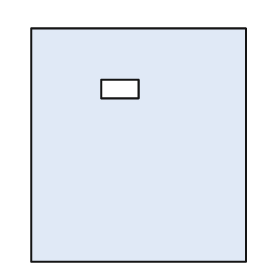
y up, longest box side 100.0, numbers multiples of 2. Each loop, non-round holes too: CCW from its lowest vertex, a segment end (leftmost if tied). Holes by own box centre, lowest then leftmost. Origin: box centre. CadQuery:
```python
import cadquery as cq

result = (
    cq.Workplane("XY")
    .moveTo(-46.0, -50.0)
    .lineTo(46.0, -50.0)
    .lineTo(46.0, 50.0)
    .lineTo(-46.0, 50.0)
    .close()
    .moveTo(-16.0, 20.0)
    .lineTo(0.0, 20.0)
    .lineTo(0.0, 28.0)
    .lineTo(-16.0, 28.0)
    .close()
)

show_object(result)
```